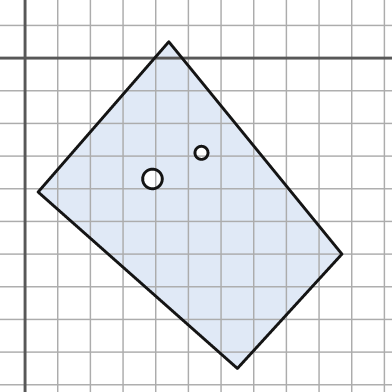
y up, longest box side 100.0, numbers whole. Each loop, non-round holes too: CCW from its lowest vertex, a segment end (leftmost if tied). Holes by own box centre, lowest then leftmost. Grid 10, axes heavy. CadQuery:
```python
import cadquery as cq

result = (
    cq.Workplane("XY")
    .moveTo(65.0, -95.0)
    .lineTo(97.0, -60.0)
    .lineTo(44.0, 5.0)
    .lineTo(4.0, -41.0)
    .close()
    .moveTo(39.0, -37.0)
    .circle(3.0)
    .moveTo(54.0, -29.0)
    .circle(2.0)
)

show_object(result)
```